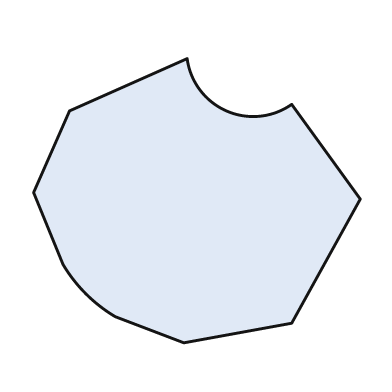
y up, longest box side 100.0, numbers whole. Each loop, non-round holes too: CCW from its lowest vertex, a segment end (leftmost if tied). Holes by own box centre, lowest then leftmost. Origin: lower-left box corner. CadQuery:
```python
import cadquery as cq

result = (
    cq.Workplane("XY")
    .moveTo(46.0, 0.0)
    .lineTo(79.0, 6.0)
    .lineTo(100.0, 44.0)
    .lineTo(79.0, 73.0)
    .threePointArc((59.0, 71.0), (47.0, 87.0))
    .lineTo(11.0, 71.0)
    .lineTo(0.0, 46.0)
    .lineTo(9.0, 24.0)
    .threePointArc((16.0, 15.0), (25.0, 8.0))
    .close()
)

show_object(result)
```